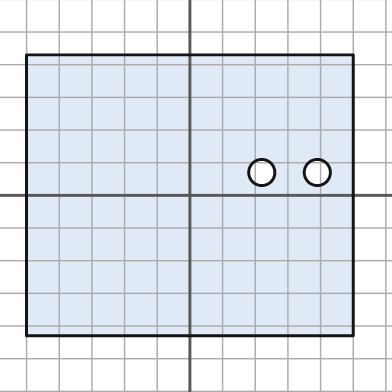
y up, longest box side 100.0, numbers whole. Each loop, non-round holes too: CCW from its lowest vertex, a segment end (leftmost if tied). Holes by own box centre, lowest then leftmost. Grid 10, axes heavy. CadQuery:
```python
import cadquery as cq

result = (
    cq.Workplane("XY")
    .moveTo(-50.0, -43.0)
    .lineTo(50.0, -43.0)
    .lineTo(50.0, 43.0)
    .lineTo(-50.0, 43.0)
    .close()
    .moveTo(22.0, 7.0)
    .circle(4.0)
    .moveTo(39.0, 7.0)
    .circle(4.0)
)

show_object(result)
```